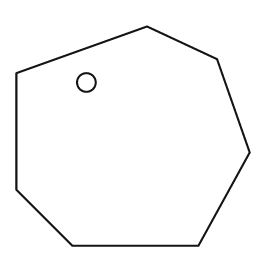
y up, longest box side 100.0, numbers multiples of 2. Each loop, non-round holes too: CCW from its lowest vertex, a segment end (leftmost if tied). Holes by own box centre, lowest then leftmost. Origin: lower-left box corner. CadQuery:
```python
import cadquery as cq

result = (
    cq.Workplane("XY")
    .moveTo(24.0, 0.0)
    .lineTo(78.0, 0.0)
    .lineTo(100.0, 40.0)
    .lineTo(86.0, 80.0)
    .lineTo(56.0, 94.0)
    .lineTo(0.0, 74.0)
    .lineTo(0.0, 24.0)
    .close()
    .moveTo(30.0, 70.0)
    .circle(4.0)
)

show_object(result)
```